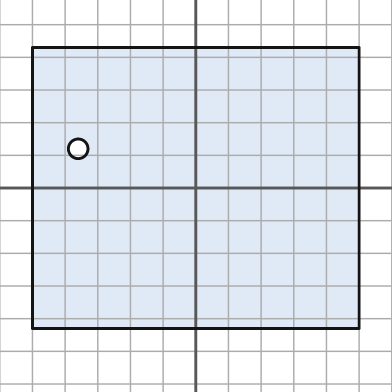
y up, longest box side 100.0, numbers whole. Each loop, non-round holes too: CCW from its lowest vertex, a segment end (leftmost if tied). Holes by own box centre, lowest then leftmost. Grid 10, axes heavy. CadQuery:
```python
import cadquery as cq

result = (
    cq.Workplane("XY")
    .moveTo(-50.0, -43.0)
    .lineTo(50.0, -43.0)
    .lineTo(50.0, 43.0)
    .lineTo(-50.0, 43.0)
    .close()
    .moveTo(-36.0, 12.0)
    .circle(3.0)
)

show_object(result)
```